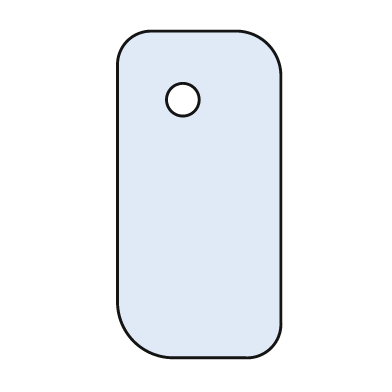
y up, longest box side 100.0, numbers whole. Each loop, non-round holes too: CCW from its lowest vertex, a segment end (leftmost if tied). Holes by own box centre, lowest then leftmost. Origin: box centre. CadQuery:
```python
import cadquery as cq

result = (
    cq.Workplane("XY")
    .moveTo(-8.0, -50.0)
    .lineTo(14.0, -50.0)
    .threePointArc((22.0, -47.0), (25.0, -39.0))
    .lineTo(25.0, 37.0)
    .threePointArc((21.0, 46.0), (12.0, 50.0))
    .lineTo(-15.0, 50.0)
    .threePointArc((-22.0, 47.0), (-25.0, 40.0))
    .lineTo(-25.0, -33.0)
    .threePointArc((-20.0, -45.0), (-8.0, -50.0))
    .close()
    .moveTo(-5.0, 29.0)
    .circle(5.0)
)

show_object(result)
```